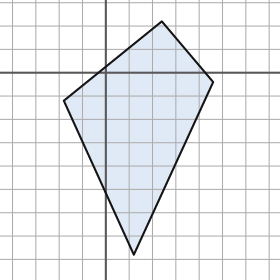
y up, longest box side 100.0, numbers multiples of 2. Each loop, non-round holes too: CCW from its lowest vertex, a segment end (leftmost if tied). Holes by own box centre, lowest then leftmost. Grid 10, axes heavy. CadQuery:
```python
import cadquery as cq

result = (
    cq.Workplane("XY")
    .moveTo(12.0, -78.0)
    .lineTo(46.0, -4.0)
    .lineTo(24.0, 22.0)
    .lineTo(-18.0, -12.0)
    .close()
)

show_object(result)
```